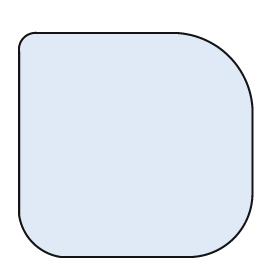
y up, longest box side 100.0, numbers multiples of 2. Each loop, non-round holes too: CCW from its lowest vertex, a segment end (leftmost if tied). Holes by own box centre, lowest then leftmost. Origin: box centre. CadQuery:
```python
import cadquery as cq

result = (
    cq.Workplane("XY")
    .moveTo(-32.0, -48.0)
    .lineTo(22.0, -48.0)
    .threePointArc((42.0, -40.0), (50.0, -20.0))
    .lineTo(50.0, 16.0)
    .threePointArc((40.0, 38.0), (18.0, 48.0))
    .lineTo(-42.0, 48.0)
    .threePointArc((-48.0, 46.0), (-50.0, 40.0))
    .lineTo(-50.0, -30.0)
    .threePointArc((-44.0, -42.0), (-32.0, -48.0))
    .close()
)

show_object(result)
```